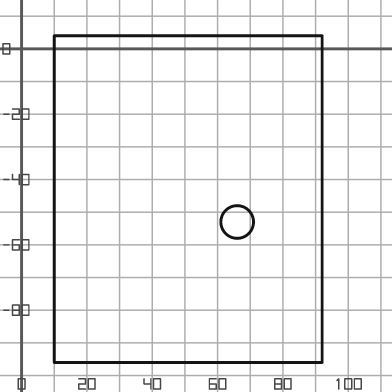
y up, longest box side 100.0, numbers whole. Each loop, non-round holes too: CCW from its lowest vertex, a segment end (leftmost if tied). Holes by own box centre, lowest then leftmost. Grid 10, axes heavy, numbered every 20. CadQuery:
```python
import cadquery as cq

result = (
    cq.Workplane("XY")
    .moveTo(10.0, -96.0)
    .lineTo(92.0, -96.0)
    .lineTo(92.0, 4.0)
    .lineTo(10.0, 4.0)
    .close()
    .moveTo(66.0, -53.0)
    .circle(5.0)
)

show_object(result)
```